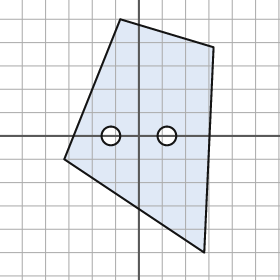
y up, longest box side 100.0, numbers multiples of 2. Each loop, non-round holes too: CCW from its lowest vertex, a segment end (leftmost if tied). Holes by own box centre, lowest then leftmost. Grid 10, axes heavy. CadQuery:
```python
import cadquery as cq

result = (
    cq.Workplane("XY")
    .moveTo(28.0, -50.0)
    .lineTo(32.0, 38.0)
    .lineTo(-8.0, 50.0)
    .lineTo(-32.0, -10.0)
    .close()
    .moveTo(-12.0, 0.0)
    .circle(4.0)
    .moveTo(12.0, 0.0)
    .circle(4.0)
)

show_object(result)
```